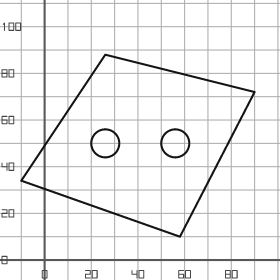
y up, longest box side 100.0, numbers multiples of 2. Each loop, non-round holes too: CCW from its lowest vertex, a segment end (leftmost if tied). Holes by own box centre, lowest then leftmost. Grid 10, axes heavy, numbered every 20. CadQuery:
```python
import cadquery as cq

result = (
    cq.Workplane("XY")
    .moveTo(58.0, 10.0)
    .lineTo(90.0, 72.0)
    .lineTo(26.0, 88.0)
    .lineTo(-10.0, 34.0)
    .close()
    .moveTo(26.0, 50.0)
    .circle(6.0)
    .moveTo(56.0, 50.0)
    .circle(6.0)
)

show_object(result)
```